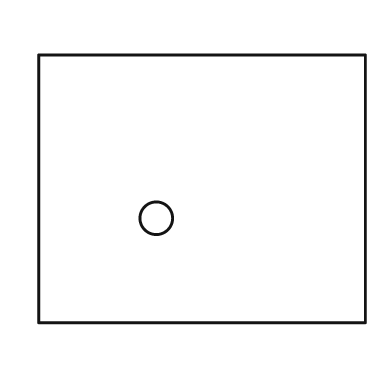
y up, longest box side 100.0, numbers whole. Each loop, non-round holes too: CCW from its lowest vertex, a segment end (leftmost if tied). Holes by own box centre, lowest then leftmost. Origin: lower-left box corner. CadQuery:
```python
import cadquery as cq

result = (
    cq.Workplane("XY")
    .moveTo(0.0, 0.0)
    .lineTo(100.0, 0.0)
    .lineTo(100.0, 82.0)
    .lineTo(0.0, 82.0)
    .close()
    .moveTo(36.0, 32.0)
    .circle(5.0)
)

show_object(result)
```